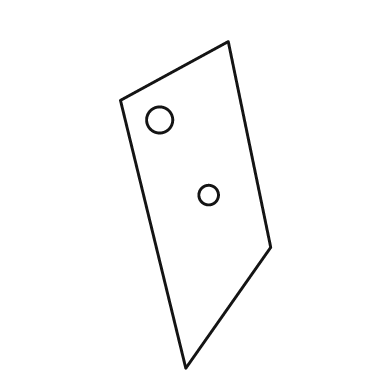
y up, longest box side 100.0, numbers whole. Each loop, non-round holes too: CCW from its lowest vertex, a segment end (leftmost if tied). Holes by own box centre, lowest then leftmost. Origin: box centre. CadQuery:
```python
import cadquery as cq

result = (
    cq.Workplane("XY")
    .moveTo(-3.0, -50.0)
    .lineTo(23.0, -13.0)
    .lineTo(10.0, 50.0)
    .lineTo(-23.0, 32.0)
    .close()
    .moveTo(4.0, 3.0)
    .circle(3.0)
    .moveTo(-11.0, 26.0)
    .circle(4.0)
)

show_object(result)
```